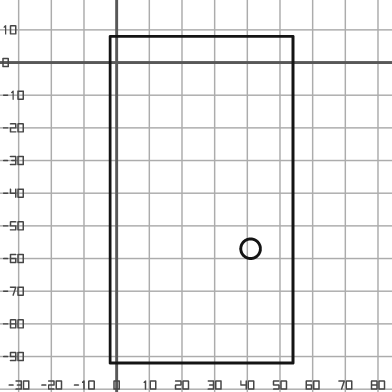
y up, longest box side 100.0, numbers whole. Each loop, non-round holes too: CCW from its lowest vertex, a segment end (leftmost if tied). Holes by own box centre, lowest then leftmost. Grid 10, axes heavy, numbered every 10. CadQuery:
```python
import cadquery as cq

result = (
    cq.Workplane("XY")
    .moveTo(-2.0, -92.0)
    .lineTo(54.0, -92.0)
    .lineTo(54.0, 8.0)
    .lineTo(-2.0, 8.0)
    .close()
    .moveTo(41.0, -57.0)
    .circle(3.0)
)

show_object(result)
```